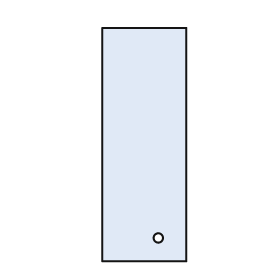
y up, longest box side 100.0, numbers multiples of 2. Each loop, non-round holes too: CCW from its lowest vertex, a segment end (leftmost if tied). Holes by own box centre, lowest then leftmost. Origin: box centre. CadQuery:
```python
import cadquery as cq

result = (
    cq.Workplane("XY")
    .moveTo(-18.0, -50.0)
    .lineTo(18.0, -50.0)
    .lineTo(18.0, 50.0)
    .lineTo(-18.0, 50.0)
    .close()
    .moveTo(6.0, -40.0)
    .circle(2.0)
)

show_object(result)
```